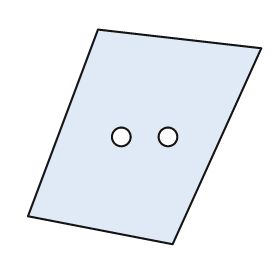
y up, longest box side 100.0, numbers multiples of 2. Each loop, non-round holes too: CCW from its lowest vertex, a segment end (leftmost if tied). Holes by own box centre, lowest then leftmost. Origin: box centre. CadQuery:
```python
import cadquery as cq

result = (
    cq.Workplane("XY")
    .moveTo(12.0, -46.0)
    .lineTo(50.0, 38.0)
    .lineTo(-20.0, 46.0)
    .lineTo(-50.0, -34.0)
    .close()
    .moveTo(-10.0, 0.0)
    .circle(4.0)
    .moveTo(10.0, 0.0)
    .circle(4.0)
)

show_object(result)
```